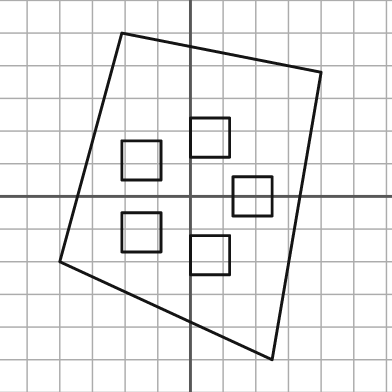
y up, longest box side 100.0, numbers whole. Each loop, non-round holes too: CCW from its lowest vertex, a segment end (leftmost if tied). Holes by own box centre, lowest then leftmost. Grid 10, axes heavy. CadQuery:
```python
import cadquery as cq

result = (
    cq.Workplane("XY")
    .moveTo(25.0, -50.0)
    .lineTo(40.0, 38.0)
    .lineTo(-21.0, 50.0)
    .lineTo(-40.0, -20.0)
    .close()
    .moveTo(0.0, -24.0)
    .lineTo(12.0, -24.0)
    .lineTo(12.0, -12.0)
    .lineTo(0.0, -12.0)
    .close()
    .moveTo(-21.0, -17.0)
    .lineTo(-9.0, -17.0)
    .lineTo(-9.0, -5.0)
    .lineTo(-21.0, -5.0)
    .close()
    .moveTo(13.0, -6.0)
    .lineTo(25.0, -6.0)
    .lineTo(25.0, 6.0)
    .lineTo(13.0, 6.0)
    .close()
    .moveTo(-21.0, 5.0)
    .lineTo(-9.0, 5.0)
    .lineTo(-9.0, 17.0)
    .lineTo(-21.0, 17.0)
    .close()
    .moveTo(0.0, 12.0)
    .lineTo(12.0, 12.0)
    .lineTo(12.0, 24.0)
    .lineTo(0.0, 24.0)
    .close()
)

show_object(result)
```